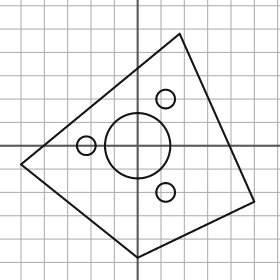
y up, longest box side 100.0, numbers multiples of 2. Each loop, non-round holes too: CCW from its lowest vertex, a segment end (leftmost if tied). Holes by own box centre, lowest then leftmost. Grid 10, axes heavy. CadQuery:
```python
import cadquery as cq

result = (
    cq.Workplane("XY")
    .moveTo(0.0, -48.0)
    .lineTo(50.0, -24.0)
    .lineTo(18.0, 48.0)
    .lineTo(-50.0, -8.0)
    .close()
    .moveTo(12.0, -20.0)
    .circle(4.0)
    .moveTo(-22.0, 0.0)
    .circle(4.0)
    .moveTo(0.0, 0.0)
    .circle(14.0)
    .moveTo(12.0, 20.0)
    .circle(4.0)
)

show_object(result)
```